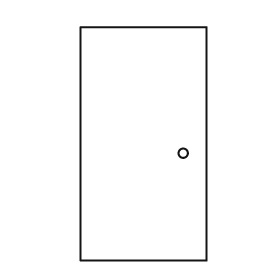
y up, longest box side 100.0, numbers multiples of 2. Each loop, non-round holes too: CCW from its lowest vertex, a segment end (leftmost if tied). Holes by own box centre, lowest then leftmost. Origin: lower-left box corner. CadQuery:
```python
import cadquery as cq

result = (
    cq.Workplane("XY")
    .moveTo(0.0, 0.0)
    .lineTo(54.0, 0.0)
    .lineTo(54.0, 100.0)
    .lineTo(0.0, 100.0)
    .close()
    .moveTo(44.0, 46.0)
    .circle(2.0)
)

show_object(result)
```